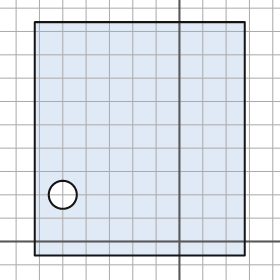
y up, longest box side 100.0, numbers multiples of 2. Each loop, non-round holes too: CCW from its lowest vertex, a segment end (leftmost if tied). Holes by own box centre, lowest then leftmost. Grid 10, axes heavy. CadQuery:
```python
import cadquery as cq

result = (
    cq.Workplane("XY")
    .moveTo(-62.0, -6.0)
    .lineTo(28.0, -6.0)
    .lineTo(28.0, 94.0)
    .lineTo(-62.0, 94.0)
    .close()
    .moveTo(-50.0, 20.0)
    .circle(6.0)
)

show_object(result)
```